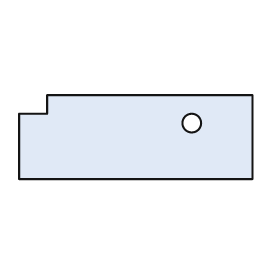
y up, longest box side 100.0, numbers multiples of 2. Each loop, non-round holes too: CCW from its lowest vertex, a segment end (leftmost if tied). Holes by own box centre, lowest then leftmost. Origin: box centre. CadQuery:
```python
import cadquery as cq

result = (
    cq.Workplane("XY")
    .moveTo(-50.0, -18.0)
    .lineTo(50.0, -18.0)
    .lineTo(50.0, 18.0)
    .lineTo(-38.0, 18.0)
    .lineTo(-38.0, 10.0)
    .lineTo(-50.0, 10.0)
    .close()
    .moveTo(24.0, 6.0)
    .circle(4.0)
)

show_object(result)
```